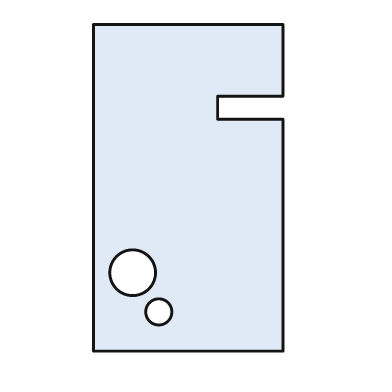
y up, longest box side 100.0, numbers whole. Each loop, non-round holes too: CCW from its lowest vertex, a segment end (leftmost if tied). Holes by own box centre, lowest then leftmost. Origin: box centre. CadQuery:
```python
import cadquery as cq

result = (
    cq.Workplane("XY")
    .moveTo(-29.0, -50.0)
    .lineTo(29.0, -50.0)
    .lineTo(29.0, 21.0)
    .lineTo(9.0, 21.0)
    .lineTo(9.0, 28.0)
    .lineTo(29.0, 28.0)
    .lineTo(29.0, 50.0)
    .lineTo(-29.0, 50.0)
    .close()
    .moveTo(-9.0, -38.0)
    .circle(4.0)
    .moveTo(-17.0, -26.0)
    .circle(7.0)
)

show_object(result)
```